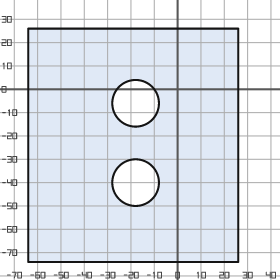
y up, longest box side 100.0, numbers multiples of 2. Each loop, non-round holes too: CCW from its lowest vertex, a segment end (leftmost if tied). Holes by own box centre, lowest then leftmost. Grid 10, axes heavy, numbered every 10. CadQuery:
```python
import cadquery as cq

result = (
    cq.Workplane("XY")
    .moveTo(-64.0, -74.0)
    .lineTo(26.0, -74.0)
    .lineTo(26.0, 26.0)
    .lineTo(-64.0, 26.0)
    .close()
    .moveTo(-18.0, -40.0)
    .circle(10.0)
    .moveTo(-18.0, -6.0)
    .circle(10.0)
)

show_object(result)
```